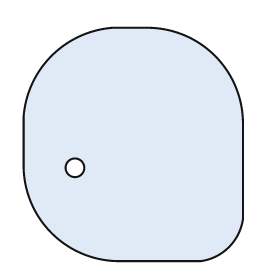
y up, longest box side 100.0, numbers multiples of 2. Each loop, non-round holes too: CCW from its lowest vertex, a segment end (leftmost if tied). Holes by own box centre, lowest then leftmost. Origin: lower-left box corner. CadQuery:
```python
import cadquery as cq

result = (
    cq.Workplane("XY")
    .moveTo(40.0, 0.0)
    .lineTo(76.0, 0.0)
    .threePointArc((88.0, 6.0), (94.0, 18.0))
    .lineTo(94.0, 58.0)
    .threePointArc((82.0, 88.0), (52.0, 100.0))
    .lineTo(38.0, 100.0)
    .threePointArc((12.0, 88.0), (0.0, 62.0))
    .lineTo(0.0, 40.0)
    .threePointArc((12.0, 12.0), (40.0, 0.0))
    .close()
    .moveTo(22.0, 40.0)
    .circle(4.0)
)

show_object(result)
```